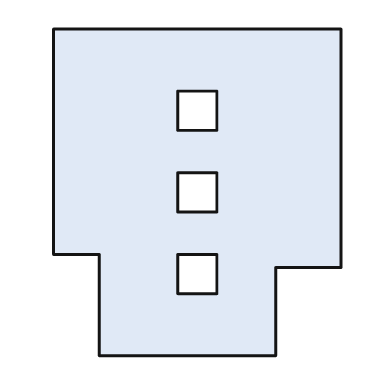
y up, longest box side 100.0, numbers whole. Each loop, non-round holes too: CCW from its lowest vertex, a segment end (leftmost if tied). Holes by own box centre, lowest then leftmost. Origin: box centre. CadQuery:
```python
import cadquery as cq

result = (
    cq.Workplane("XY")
    .moveTo(-30.0, -50.0)
    .lineTo(24.0, -50.0)
    .lineTo(24.0, -23.0)
    .lineTo(44.0, -23.0)
    .lineTo(44.0, 50.0)
    .lineTo(-44.0, 50.0)
    .lineTo(-44.0, -19.0)
    .lineTo(-30.0, -19.0)
    .close()
    .moveTo(-6.0, -31.0)
    .lineTo(6.0, -31.0)
    .lineTo(6.0, -19.0)
    .lineTo(-6.0, -19.0)
    .close()
    .moveTo(-6.0, -6.0)
    .lineTo(6.0, -6.0)
    .lineTo(6.0, 6.0)
    .lineTo(-6.0, 6.0)
    .close()
    .moveTo(-6.0, 19.0)
    .lineTo(6.0, 19.0)
    .lineTo(6.0, 31.0)
    .lineTo(-6.0, 31.0)
    .close()
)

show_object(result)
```